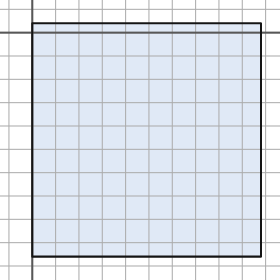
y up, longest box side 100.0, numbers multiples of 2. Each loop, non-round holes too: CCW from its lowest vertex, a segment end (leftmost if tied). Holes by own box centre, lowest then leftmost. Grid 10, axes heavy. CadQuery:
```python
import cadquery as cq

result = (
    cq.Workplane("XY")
    .moveTo(0.0, -96.0)
    .lineTo(98.0, -96.0)
    .lineTo(98.0, 4.0)
    .lineTo(0.0, 4.0)
    .close()
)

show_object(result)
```